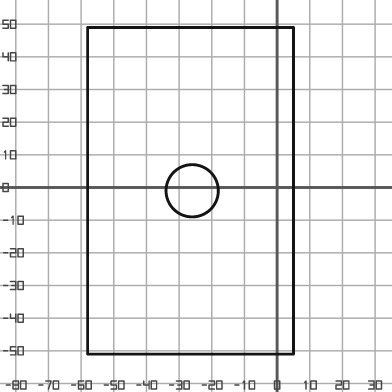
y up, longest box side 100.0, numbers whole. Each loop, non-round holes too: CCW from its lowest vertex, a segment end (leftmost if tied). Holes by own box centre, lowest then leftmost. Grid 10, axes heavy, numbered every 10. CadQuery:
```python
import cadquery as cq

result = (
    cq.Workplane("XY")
    .moveTo(-58.0, -51.0)
    .lineTo(5.0, -51.0)
    .lineTo(5.0, 49.0)
    .lineTo(-58.0, 49.0)
    .close()
    .moveTo(-26.0, -1.0)
    .circle(8.0)
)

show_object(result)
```